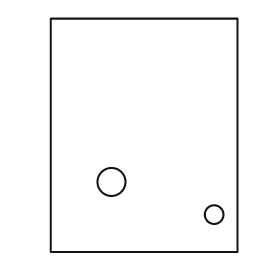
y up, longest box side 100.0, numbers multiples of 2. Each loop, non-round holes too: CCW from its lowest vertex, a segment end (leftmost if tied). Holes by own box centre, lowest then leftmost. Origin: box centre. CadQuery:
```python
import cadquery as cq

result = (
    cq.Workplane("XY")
    .moveTo(-40.0, -50.0)
    .lineTo(40.0, -50.0)
    .lineTo(40.0, 50.0)
    .lineTo(-40.0, 50.0)
    .close()
    .moveTo(30.0, -34.0)
    .circle(4.0)
    .moveTo(-14.0, -20.0)
    .circle(6.0)
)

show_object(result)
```